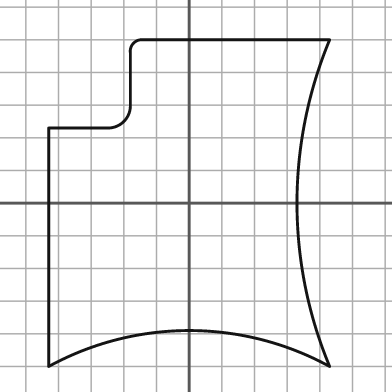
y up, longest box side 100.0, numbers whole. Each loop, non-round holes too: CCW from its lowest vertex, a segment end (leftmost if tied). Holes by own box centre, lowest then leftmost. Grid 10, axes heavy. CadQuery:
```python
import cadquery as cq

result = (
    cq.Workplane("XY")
    .moveTo(-43.0, -50.0)
    .threePointArc((0.0, -39.0), (43.0, -50.0))
    .threePointArc((33.0, 0.0), (43.0, 50.0))
    .lineTo(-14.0, 50.0)
    .threePointArc((-17.0, 49.0), (-18.0, 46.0))
    .lineTo(-18.0, 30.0)
    .threePointArc((-20.0, 25.0), (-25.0, 23.0))
    .lineTo(-43.0, 23.0)
    .close()
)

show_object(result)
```